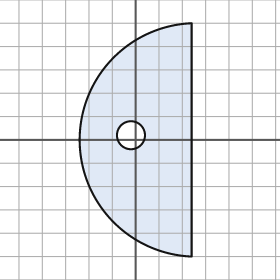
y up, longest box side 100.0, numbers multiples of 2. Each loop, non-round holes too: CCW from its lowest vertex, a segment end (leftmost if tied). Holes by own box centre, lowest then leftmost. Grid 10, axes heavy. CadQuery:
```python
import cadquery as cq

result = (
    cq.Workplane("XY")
    .moveTo(24.0, -50.0)
    .lineTo(24.0, 50.0)
    .threePointArc((-24.0, 0.0), (24.0, -50.0))
    .close()
    .moveTo(-2.0, 2.0)
    .circle(6.0)
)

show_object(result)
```